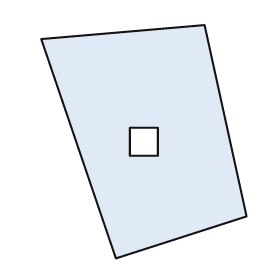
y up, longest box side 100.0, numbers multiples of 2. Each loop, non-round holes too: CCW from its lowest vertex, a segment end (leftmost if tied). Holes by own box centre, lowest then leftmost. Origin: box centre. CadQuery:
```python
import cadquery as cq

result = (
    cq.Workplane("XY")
    .moveTo(-12.0, -50.0)
    .lineTo(44.0, -32.0)
    .lineTo(26.0, 50.0)
    .lineTo(-44.0, 44.0)
    .close()
    .moveTo(-6.0, -6.0)
    .lineTo(6.0, -6.0)
    .lineTo(6.0, 6.0)
    .lineTo(-6.0, 6.0)
    .close()
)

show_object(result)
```